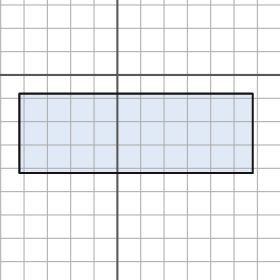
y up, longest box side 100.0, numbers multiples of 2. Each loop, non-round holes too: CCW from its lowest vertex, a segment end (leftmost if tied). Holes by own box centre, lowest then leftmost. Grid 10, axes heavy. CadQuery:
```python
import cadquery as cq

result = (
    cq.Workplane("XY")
    .moveTo(-42.0, -42.0)
    .lineTo(58.0, -42.0)
    .lineTo(58.0, -8.0)
    .lineTo(-42.0, -8.0)
    .close()
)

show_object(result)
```